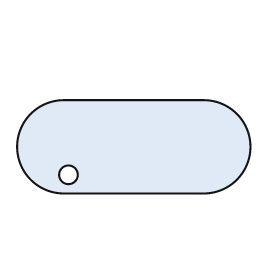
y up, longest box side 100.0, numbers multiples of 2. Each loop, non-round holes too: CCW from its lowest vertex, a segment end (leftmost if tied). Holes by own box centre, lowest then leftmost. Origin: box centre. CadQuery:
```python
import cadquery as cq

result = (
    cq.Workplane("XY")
    .moveTo(-30.0, -20.0)
    .lineTo(30.0, -20.0)
    .threePointArc((50.0, 0.0), (30.0, 20.0))
    .lineTo(-30.0, 20.0)
    .threePointArc((-50.0, 0.0), (-30.0, -20.0))
    .close()
    .moveTo(-28.0, -12.0)
    .circle(4.0)
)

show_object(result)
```